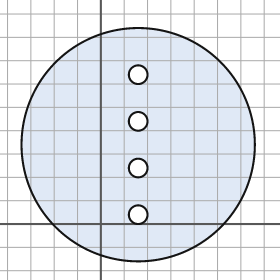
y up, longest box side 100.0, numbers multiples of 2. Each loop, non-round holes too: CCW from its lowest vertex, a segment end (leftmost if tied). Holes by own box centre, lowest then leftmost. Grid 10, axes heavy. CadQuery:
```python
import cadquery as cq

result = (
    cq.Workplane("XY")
    .moveTo(16.0, 34.0)
    .circle(50.0)
    .moveTo(16.0, 4.0)
    .circle(4.0)
    .moveTo(16.0, 24.0)
    .circle(4.0)
    .moveTo(16.0, 44.0)
    .circle(4.0)
    .moveTo(16.0, 64.0)
    .circle(4.0)
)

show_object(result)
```